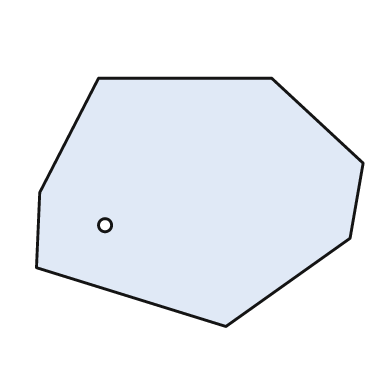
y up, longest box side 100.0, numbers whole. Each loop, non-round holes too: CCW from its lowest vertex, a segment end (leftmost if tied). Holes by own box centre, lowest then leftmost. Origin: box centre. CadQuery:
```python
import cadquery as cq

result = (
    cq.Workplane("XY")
    .moveTo(8.0, -38.0)
    .lineTo(46.0, -11.0)
    .lineTo(50.0, 12.0)
    .lineTo(22.0, 38.0)
    .lineTo(-31.0, 38.0)
    .lineTo(-49.0, 3.0)
    .lineTo(-50.0, -20.0)
    .close()
    .moveTo(-29.0, -7.0)
    .circle(2.0)
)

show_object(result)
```